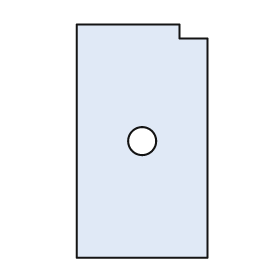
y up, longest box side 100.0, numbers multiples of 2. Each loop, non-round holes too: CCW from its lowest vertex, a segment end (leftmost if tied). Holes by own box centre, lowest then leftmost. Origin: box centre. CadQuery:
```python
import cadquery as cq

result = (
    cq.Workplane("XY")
    .moveTo(-28.0, -50.0)
    .lineTo(28.0, -50.0)
    .lineTo(28.0, 44.0)
    .lineTo(16.0, 44.0)
    .lineTo(16.0, 50.0)
    .lineTo(-28.0, 50.0)
    .close()
    .moveTo(0.0, 0.0)
    .circle(6.0)
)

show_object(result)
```